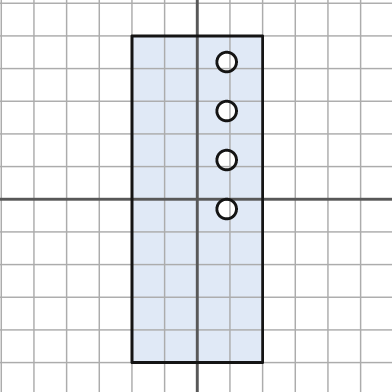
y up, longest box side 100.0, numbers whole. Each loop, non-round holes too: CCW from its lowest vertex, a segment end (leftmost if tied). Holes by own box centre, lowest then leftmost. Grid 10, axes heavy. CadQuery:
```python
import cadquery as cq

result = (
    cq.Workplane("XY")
    .moveTo(-20.0, -50.0)
    .lineTo(20.0, -50.0)
    .lineTo(20.0, 50.0)
    .lineTo(-20.0, 50.0)
    .close()
    .moveTo(9.0, -3.0)
    .circle(3.0)
    .moveTo(9.0, 12.0)
    .circle(3.0)
    .moveTo(9.0, 27.0)
    .circle(3.0)
    .moveTo(9.0, 42.0)
    .circle(3.0)
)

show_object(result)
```